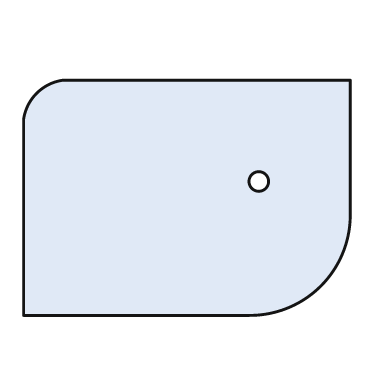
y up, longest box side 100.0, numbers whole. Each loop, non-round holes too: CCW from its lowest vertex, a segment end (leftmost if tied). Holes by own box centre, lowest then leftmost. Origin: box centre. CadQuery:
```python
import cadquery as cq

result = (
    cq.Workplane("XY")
    .moveTo(-50.0, -36.0)
    .lineTo(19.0, -36.0)
    .threePointArc((41.0, -27.0), (50.0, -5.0))
    .lineTo(50.0, 36.0)
    .lineTo(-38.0, 36.0)
    .threePointArc((-46.0, 32.0), (-50.0, 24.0))
    .close()
    .moveTo(22.0, 5.0)
    .circle(3.0)
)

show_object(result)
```